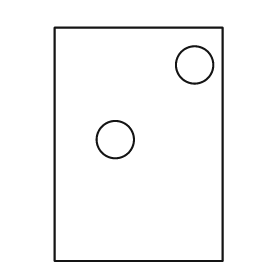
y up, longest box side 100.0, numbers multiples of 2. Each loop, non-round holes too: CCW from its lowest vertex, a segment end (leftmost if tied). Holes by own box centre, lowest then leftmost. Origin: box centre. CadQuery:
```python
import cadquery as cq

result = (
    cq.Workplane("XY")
    .moveTo(-36.0, -50.0)
    .lineTo(36.0, -50.0)
    .lineTo(36.0, 50.0)
    .lineTo(-36.0, 50.0)
    .close()
    .moveTo(-10.0, 2.0)
    .circle(8.0)
    .moveTo(24.0, 34.0)
    .circle(8.0)
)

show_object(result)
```